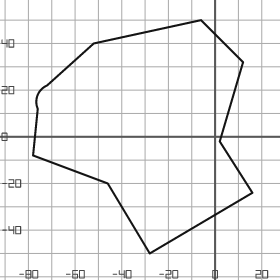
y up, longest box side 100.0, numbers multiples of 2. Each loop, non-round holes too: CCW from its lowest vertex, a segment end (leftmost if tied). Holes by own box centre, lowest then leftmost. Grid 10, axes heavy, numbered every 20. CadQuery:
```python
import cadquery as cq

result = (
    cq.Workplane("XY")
    .moveTo(-28.0, -50.0)
    .lineTo(16.0, -24.0)
    .lineTo(2.0, -2.0)
    .lineTo(12.0, 32.0)
    .lineTo(-6.0, 50.0)
    .lineTo(-52.0, 40.0)
    .lineTo(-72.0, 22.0)
    .threePointArc((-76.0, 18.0), (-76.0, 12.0))
    .lineTo(-78.0, -8.0)
    .lineTo(-46.0, -20.0)
    .close()
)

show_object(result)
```